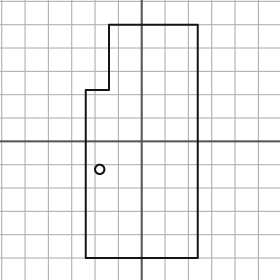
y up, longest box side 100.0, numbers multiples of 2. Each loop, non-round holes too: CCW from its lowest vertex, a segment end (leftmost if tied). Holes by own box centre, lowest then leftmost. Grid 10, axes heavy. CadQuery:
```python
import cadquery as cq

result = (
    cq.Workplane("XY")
    .moveTo(-24.0, -50.0)
    .lineTo(24.0, -50.0)
    .lineTo(24.0, 50.0)
    .lineTo(-14.0, 50.0)
    .lineTo(-14.0, 22.0)
    .lineTo(-24.0, 22.0)
    .close()
    .moveTo(-18.0, -12.0)
    .circle(2.0)
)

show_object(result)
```